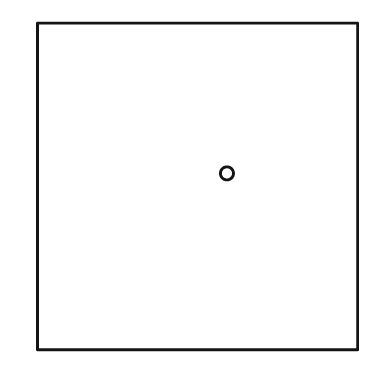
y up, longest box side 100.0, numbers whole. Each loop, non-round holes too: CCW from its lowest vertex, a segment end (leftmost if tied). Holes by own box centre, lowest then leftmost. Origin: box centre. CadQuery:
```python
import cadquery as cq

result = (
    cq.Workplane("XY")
    .moveTo(-49.0, -50.0)
    .lineTo(49.0, -50.0)
    .lineTo(49.0, 50.0)
    .lineTo(-49.0, 50.0)
    .close()
    .moveTo(9.0, 4.0)
    .circle(2.0)
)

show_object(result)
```